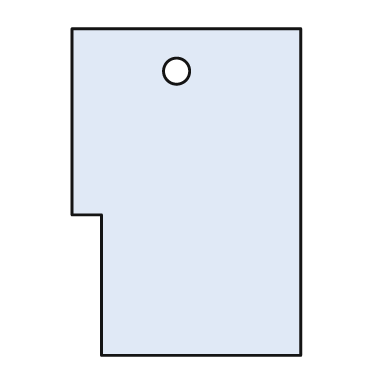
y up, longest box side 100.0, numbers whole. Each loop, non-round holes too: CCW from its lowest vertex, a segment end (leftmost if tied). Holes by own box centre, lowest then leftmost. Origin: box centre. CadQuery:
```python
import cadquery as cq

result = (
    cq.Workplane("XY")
    .moveTo(-26.0, -50.0)
    .lineTo(35.0, -50.0)
    .lineTo(35.0, 50.0)
    .lineTo(-35.0, 50.0)
    .lineTo(-35.0, -7.0)
    .lineTo(-26.0, -7.0)
    .close()
    .moveTo(-3.0, 37.0)
    .circle(4.0)
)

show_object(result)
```